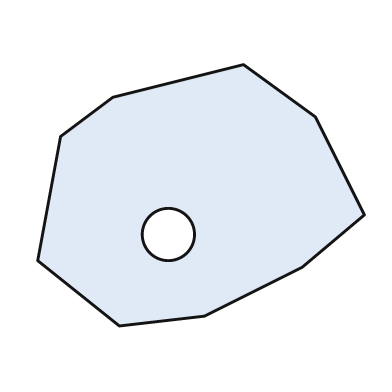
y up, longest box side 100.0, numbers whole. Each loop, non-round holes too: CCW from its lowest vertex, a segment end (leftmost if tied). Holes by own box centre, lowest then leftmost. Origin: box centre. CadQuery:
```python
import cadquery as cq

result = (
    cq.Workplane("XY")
    .moveTo(-25.0, -40.0)
    .lineTo(1.0, -37.0)
    .lineTo(31.0, -22.0)
    .lineTo(50.0, -6.0)
    .lineTo(35.0, 24.0)
    .lineTo(13.0, 40.0)
    .lineTo(-27.0, 30.0)
    .lineTo(-43.0, 18.0)
    .lineTo(-50.0, -20.0)
    .close()
    .moveTo(-10.0, -12.0)
    .circle(8.0)
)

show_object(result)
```